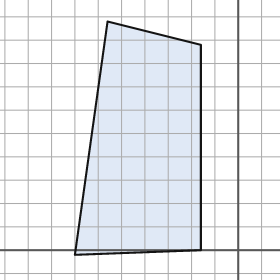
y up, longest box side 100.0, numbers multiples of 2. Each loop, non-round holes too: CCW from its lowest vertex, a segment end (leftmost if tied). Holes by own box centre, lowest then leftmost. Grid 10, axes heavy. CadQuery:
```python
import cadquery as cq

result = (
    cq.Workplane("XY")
    .moveTo(-70.0, -2.0)
    .lineTo(-16.0, 0.0)
    .lineTo(-16.0, 88.0)
    .lineTo(-56.0, 98.0)
    .close()
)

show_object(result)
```